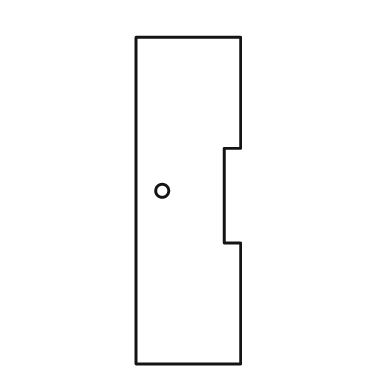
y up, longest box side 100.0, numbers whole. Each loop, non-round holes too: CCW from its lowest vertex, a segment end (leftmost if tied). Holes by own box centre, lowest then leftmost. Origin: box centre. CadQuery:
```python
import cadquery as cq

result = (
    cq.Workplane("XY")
    .moveTo(-16.0, -50.0)
    .lineTo(16.0, -50.0)
    .lineTo(16.0, -13.0)
    .lineTo(11.0, -13.0)
    .lineTo(11.0, 16.0)
    .lineTo(16.0, 16.0)
    .lineTo(16.0, 50.0)
    .lineTo(-16.0, 50.0)
    .close()
    .moveTo(-8.0, 3.0)
    .circle(2.0)
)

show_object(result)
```